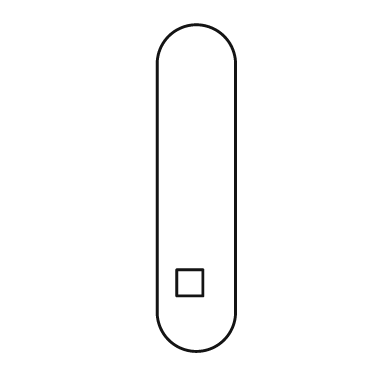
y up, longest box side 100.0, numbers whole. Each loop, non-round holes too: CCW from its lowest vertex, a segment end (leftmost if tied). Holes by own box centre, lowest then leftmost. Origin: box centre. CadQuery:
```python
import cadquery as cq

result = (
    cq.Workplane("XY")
    .moveTo(-12.0, -38.0)
    .threePointArc((0.0, -50.0), (12.0, -38.0))
    .lineTo(12.0, 38.0)
    .threePointArc((0.0, 50.0), (-12.0, 38.0))
    .close()
    .moveTo(-6.0, -33.0)
    .lineTo(2.0, -33.0)
    .lineTo(2.0, -25.0)
    .lineTo(-6.0, -25.0)
    .close()
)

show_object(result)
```